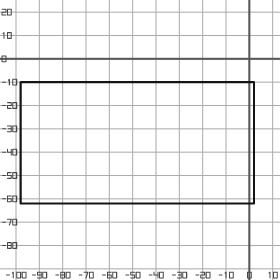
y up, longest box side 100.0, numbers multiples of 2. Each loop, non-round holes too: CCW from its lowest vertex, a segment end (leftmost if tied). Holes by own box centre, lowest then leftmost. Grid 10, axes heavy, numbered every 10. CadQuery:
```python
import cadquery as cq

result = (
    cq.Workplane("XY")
    .moveTo(-98.0, -62.0)
    .lineTo(2.0, -62.0)
    .lineTo(2.0, -10.0)
    .lineTo(-98.0, -10.0)
    .close()
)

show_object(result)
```